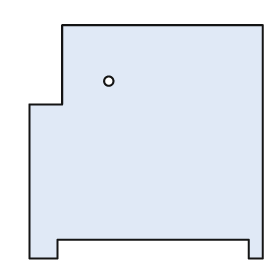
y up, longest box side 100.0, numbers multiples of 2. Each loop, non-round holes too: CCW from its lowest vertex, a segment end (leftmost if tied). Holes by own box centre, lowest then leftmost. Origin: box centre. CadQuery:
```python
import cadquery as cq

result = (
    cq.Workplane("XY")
    .moveTo(-50.0, -50.0)
    .lineTo(-38.0, -50.0)
    .lineTo(-38.0, -42.0)
    .lineTo(44.0, -42.0)
    .lineTo(44.0, -50.0)
    .lineTo(50.0, -50.0)
    .lineTo(50.0, 50.0)
    .lineTo(-36.0, 50.0)
    .lineTo(-36.0, 16.0)
    .lineTo(-50.0, 16.0)
    .close()
    .moveTo(-16.0, 26.0)
    .circle(2.0)
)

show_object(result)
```